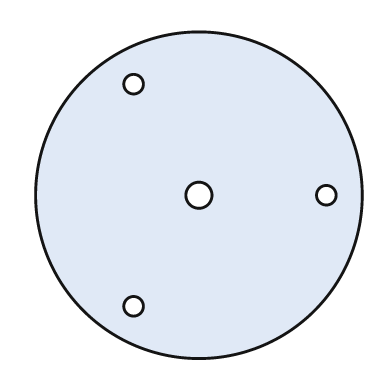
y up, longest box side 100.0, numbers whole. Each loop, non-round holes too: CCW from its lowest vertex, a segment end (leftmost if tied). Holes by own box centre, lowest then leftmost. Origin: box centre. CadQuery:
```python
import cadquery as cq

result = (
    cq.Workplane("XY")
    .moveTo(0.0, 0.0)
    .circle(50.0)
    .moveTo(-20.0, -34.0)
    .circle(3.0)
    .moveTo(0.0, 0.0)
    .circle(4.0)
    .moveTo(39.0, 0.0)
    .circle(3.0)
    .moveTo(-20.0, 34.0)
    .circle(3.0)
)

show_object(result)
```